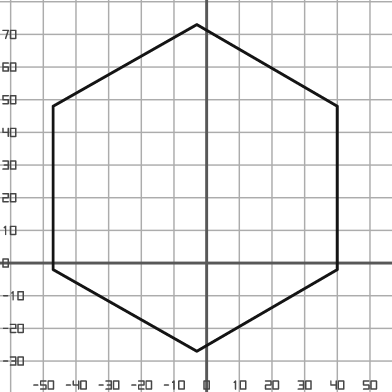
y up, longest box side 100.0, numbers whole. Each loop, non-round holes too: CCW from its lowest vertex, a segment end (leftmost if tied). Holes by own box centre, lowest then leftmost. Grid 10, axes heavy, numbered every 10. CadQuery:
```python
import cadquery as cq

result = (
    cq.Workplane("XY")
    .moveTo(-3.0, -27.0)
    .lineTo(40.0, -2.0)
    .lineTo(40.0, 48.0)
    .lineTo(-3.0, 73.0)
    .lineTo(-47.0, 48.0)
    .lineTo(-47.0, -2.0)
    .close()
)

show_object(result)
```